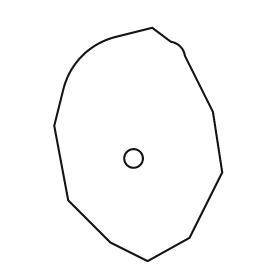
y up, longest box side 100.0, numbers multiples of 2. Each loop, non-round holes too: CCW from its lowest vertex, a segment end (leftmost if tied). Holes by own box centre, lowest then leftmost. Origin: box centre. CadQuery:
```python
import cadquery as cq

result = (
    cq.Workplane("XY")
    .moveTo(4.0, -50.0)
    .lineTo(22.0, -40.0)
    .lineTo(36.0, -12.0)
    .lineTo(32.0, 14.0)
    .lineTo(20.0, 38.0)
    .threePointArc((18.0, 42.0), (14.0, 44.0))
    .lineTo(6.0, 50.0)
    .lineTo(-10.0, 46.0)
    .threePointArc((-24.0, 38.0), (-32.0, 24.0))
    .lineTo(-36.0, 8.0)
    .lineTo(-30.0, -24.0)
    .lineTo(-12.0, -42.0)
    .close()
    .moveTo(-2.0, -6.0)
    .circle(4.0)
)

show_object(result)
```